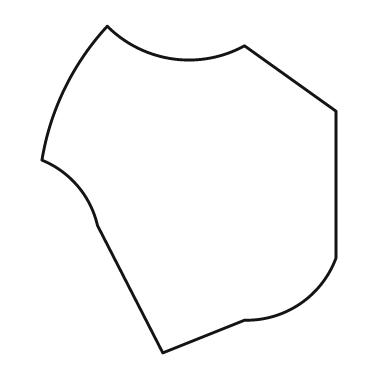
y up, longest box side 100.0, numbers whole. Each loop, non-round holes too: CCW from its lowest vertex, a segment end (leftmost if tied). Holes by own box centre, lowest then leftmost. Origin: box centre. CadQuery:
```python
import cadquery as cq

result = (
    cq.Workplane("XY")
    .moveTo(-8.0, -50.0)
    .lineTo(17.0, -40.0)
    .threePointArc((34.0, -35.0), (45.0, -21.0))
    .lineTo(45.0, 24.0)
    .lineTo(17.0, 44.0)
    .threePointArc((-5.0, 40.0), (-25.0, 50.0))
    .threePointArc((-38.0, 31.0), (-45.0, 9.0))
    .threePointArc((-34.0, 1.0), (-28.0, -11.0))
    .close()
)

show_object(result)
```